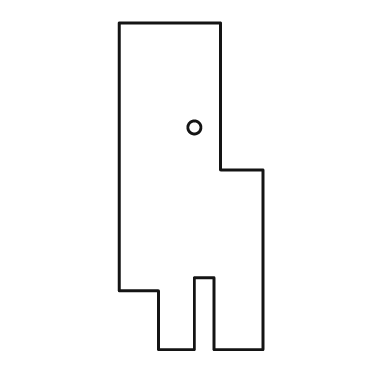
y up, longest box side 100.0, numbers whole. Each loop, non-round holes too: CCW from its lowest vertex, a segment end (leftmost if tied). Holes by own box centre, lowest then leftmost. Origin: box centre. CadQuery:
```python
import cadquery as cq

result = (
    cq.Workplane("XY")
    .moveTo(-10.0, -50.0)
    .lineTo(1.0, -50.0)
    .lineTo(1.0, -28.0)
    .lineTo(7.0, -28.0)
    .lineTo(7.0, -50.0)
    .lineTo(22.0, -50.0)
    .lineTo(22.0, 5.0)
    .lineTo(9.0, 5.0)
    .lineTo(9.0, 50.0)
    .lineTo(-22.0, 50.0)
    .lineTo(-22.0, -32.0)
    .lineTo(-10.0, -32.0)
    .close()
    .moveTo(1.0, 18.0)
    .circle(2.0)
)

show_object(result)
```